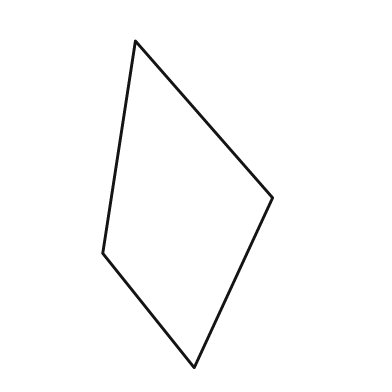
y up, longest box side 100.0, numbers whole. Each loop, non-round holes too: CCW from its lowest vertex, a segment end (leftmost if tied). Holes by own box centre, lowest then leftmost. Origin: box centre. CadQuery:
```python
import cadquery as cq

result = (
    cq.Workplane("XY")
    .moveTo(2.0, -50.0)
    .lineTo(26.0, 2.0)
    .lineTo(-16.0, 50.0)
    .lineTo(-26.0, -15.0)
    .close()
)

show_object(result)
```